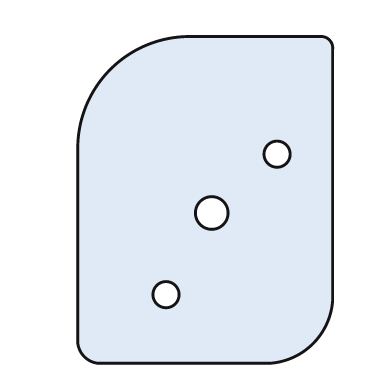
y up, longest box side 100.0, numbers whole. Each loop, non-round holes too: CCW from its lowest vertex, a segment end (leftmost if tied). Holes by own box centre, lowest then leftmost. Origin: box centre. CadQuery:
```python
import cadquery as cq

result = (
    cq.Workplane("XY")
    .moveTo(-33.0, -50.0)
    .lineTo(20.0, -50.0)
    .threePointArc((33.0, -44.0), (39.0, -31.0))
    .lineTo(39.0, 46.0)
    .threePointArc((38.0, 49.0), (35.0, 50.0))
    .lineTo(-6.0, 50.0)
    .threePointArc((-29.0, 40.0), (-39.0, 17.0))
    .lineTo(-39.0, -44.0)
    .threePointArc((-37.0, -48.0), (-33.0, -50.0))
    .close()
    .moveTo(-12.0, -29.0)
    .circle(4.0)
    .moveTo(2.0, -4.0)
    .circle(5.0)
    .moveTo(22.0, 14.0)
    .circle(4.0)
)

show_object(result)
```